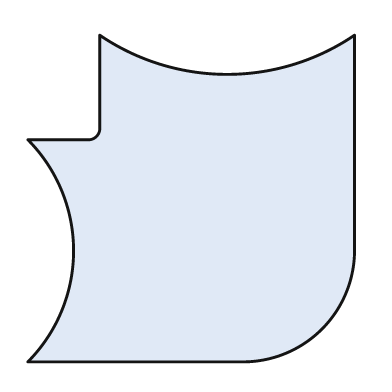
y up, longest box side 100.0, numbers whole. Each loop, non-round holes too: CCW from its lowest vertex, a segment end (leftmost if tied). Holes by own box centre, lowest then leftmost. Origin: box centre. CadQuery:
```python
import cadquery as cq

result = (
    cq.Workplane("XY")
    .moveTo(-50.0, -50.0)
    .lineTo(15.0, -50.0)
    .threePointArc((40.0, -40.0), (50.0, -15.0))
    .lineTo(50.0, 50.0)
    .threePointArc((11.0, 38.0), (-28.0, 50.0))
    .lineTo(-28.0, 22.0)
    .threePointArc((-29.0, 19.0), (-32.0, 18.0))
    .lineTo(-50.0, 18.0)
    .threePointArc((-36.0, -16.0), (-50.0, -50.0))
    .close()
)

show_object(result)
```